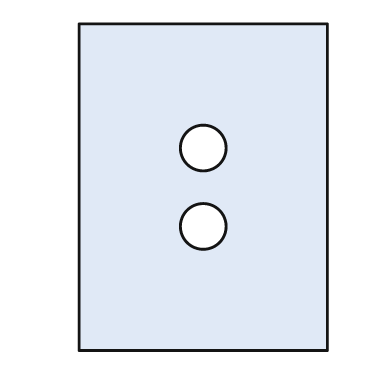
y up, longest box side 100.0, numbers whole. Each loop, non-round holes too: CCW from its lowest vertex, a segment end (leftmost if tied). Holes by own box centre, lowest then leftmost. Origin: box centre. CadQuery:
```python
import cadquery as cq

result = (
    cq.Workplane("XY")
    .moveTo(-38.0, -50.0)
    .lineTo(38.0, -50.0)
    .lineTo(38.0, 50.0)
    .lineTo(-38.0, 50.0)
    .close()
    .moveTo(0.0, -12.0)
    .circle(7.0)
    .moveTo(0.0, 12.0)
    .circle(7.0)
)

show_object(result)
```